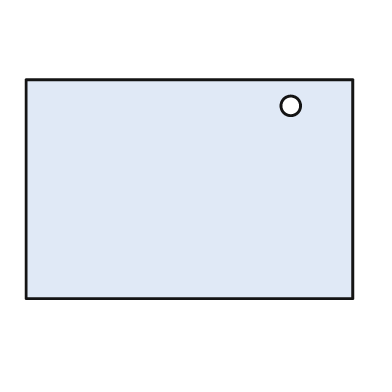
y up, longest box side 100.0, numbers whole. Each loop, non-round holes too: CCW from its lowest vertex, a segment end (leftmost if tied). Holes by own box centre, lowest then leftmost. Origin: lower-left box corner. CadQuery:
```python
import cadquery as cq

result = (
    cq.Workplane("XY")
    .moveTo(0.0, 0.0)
    .lineTo(100.0, 0.0)
    .lineTo(100.0, 67.0)
    .lineTo(0.0, 67.0)
    .close()
    .moveTo(81.0, 59.0)
    .circle(3.0)
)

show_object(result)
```